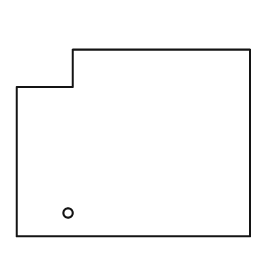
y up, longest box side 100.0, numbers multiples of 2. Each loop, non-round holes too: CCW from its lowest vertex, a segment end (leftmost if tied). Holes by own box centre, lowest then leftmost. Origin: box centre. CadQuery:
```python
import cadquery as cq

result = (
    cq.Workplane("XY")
    .moveTo(-50.0, -40.0)
    .lineTo(50.0, -40.0)
    .lineTo(50.0, 40.0)
    .lineTo(-26.0, 40.0)
    .lineTo(-26.0, 24.0)
    .lineTo(-50.0, 24.0)
    .close()
    .moveTo(-28.0, -30.0)
    .circle(2.0)
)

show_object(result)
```